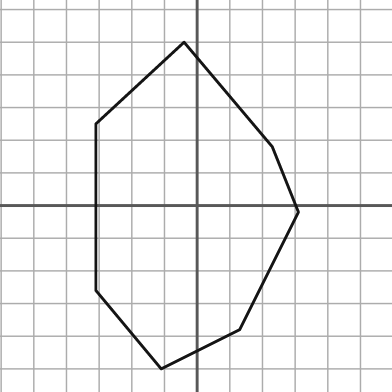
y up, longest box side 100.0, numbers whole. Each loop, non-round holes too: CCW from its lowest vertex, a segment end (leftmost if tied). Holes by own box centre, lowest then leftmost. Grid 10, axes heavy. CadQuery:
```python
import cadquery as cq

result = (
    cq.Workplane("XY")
    .moveTo(-11.0, -50.0)
    .lineTo(13.0, -38.0)
    .lineTo(31.0, -2.0)
    .lineTo(23.0, 18.0)
    .lineTo(-4.0, 50.0)
    .lineTo(-31.0, 25.0)
    .lineTo(-31.0, -26.0)
    .close()
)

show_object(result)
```